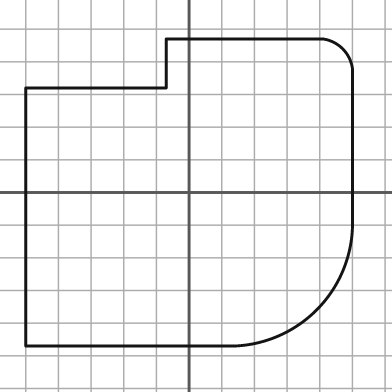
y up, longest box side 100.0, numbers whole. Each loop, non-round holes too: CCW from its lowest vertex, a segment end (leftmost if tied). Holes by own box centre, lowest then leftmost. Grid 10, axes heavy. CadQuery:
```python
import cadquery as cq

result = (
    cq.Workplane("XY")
    .moveTo(-50.0, -47.0)
    .lineTo(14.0, -47.0)
    .threePointArc((39.0, -36.0), (50.0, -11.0))
    .lineTo(50.0, 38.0)
    .threePointArc((47.0, 44.0), (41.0, 47.0))
    .lineTo(-7.0, 47.0)
    .lineTo(-7.0, 32.0)
    .lineTo(-50.0, 32.0)
    .close()
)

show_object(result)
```